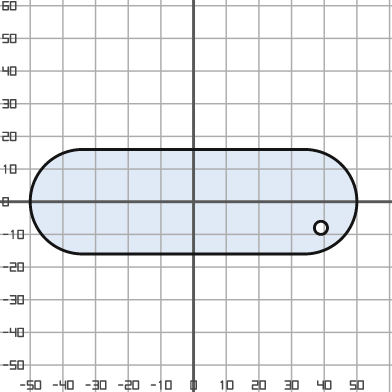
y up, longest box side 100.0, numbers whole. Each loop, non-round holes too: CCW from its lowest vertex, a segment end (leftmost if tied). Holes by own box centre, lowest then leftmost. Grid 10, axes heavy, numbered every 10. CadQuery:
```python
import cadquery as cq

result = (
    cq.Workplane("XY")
    .moveTo(-34.0, -16.0)
    .lineTo(34.0, -16.0)
    .threePointArc((50.0, 0.0), (34.0, 16.0))
    .lineTo(-34.0, 16.0)
    .threePointArc((-50.0, 0.0), (-34.0, -16.0))
    .close()
    .moveTo(39.0, -8.0)
    .circle(2.0)
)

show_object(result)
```